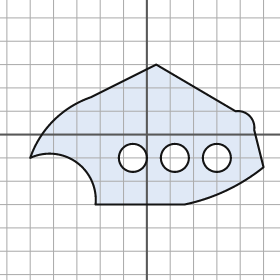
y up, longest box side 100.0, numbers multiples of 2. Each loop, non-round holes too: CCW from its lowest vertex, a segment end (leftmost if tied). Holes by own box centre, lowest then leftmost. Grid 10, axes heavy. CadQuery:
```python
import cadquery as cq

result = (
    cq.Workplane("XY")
    .moveTo(-22.0, -30.0)
    .lineTo(16.0, -30.0)
    .threePointArc((34.0, -24.0), (50.0, -14.0))
    .lineTo(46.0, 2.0)
    .threePointArc((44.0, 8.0), (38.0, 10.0))
    .lineTo(4.0, 30.0)
    .lineTo(-24.0, 16.0)
    .threePointArc((-40.0, 6.0), (-50.0, -10.0))
    .threePointArc((-30.0, -12.0), (-22.0, -30.0))
    .close()
    .moveTo(-6.0, -10.0)
    .circle(6.0)
    .moveTo(12.0, -10.0)
    .circle(6.0)
    .moveTo(30.0, -10.0)
    .circle(6.0)
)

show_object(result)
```